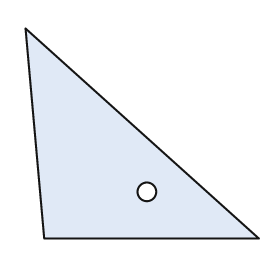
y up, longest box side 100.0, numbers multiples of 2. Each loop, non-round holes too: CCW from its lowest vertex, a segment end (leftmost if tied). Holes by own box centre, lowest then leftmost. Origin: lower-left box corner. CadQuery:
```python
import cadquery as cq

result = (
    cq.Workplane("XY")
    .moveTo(8.0, 0.0)
    .lineTo(100.0, 0.0)
    .lineTo(0.0, 90.0)
    .close()
    .moveTo(52.0, 20.0)
    .circle(4.0)
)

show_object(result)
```